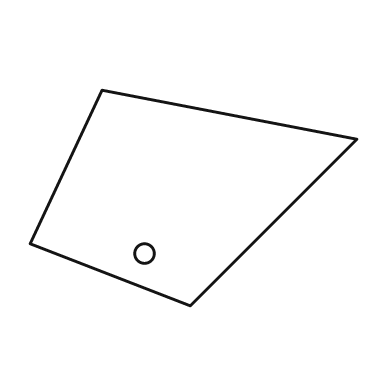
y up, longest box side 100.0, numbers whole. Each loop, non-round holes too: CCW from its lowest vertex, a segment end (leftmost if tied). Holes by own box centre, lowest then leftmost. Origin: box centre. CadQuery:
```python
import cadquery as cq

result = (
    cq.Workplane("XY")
    .moveTo(-1.0, -33.0)
    .lineTo(50.0, 18.0)
    .lineTo(-28.0, 33.0)
    .lineTo(-50.0, -14.0)
    .close()
    .moveTo(-15.0, -17.0)
    .circle(3.0)
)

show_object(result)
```